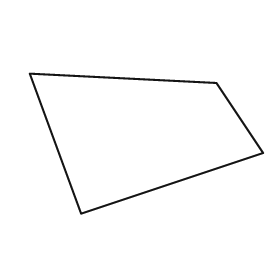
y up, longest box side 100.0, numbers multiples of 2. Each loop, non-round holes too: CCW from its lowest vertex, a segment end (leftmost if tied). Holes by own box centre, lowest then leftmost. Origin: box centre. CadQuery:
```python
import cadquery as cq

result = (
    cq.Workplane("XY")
    .moveTo(-28.0, -30.0)
    .lineTo(50.0, -4.0)
    .lineTo(30.0, 26.0)
    .lineTo(-50.0, 30.0)
    .close()
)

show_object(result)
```